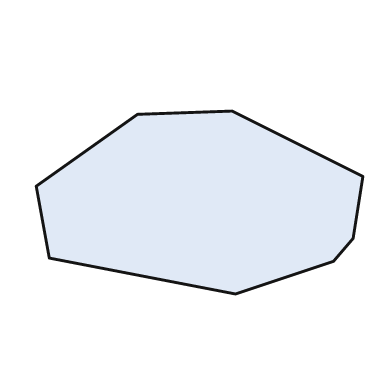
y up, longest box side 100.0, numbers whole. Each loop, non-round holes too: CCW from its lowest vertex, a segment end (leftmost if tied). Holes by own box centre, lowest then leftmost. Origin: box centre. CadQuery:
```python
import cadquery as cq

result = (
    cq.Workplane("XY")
    .moveTo(11.0, -28.0)
    .lineTo(41.0, -18.0)
    .lineTo(47.0, -11.0)
    .lineTo(50.0, 8.0)
    .lineTo(10.0, 28.0)
    .lineTo(-19.0, 27.0)
    .lineTo(-50.0, 5.0)
    .lineTo(-46.0, -17.0)
    .close()
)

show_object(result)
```